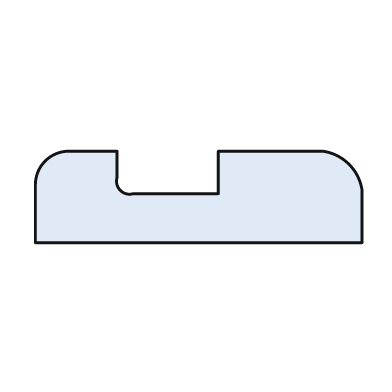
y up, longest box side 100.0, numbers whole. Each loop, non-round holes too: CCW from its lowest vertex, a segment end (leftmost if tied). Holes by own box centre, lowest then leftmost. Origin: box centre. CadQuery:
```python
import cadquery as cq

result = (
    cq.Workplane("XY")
    .moveTo(-50.0, -14.0)
    .lineTo(50.0, -14.0)
    .lineTo(50.0, 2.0)
    .threePointArc((46.0, 10.0), (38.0, 14.0))
    .lineTo(6.0, 14.0)
    .lineTo(6.0, 1.0)
    .lineTo(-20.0, 1.0)
    .threePointArc((-24.0, 2.0), (-25.0, 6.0))
    .lineTo(-25.0, 14.0)
    .lineTo(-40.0, 14.0)
    .threePointArc((-47.0, 11.0), (-50.0, 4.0))
    .close()
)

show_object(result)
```